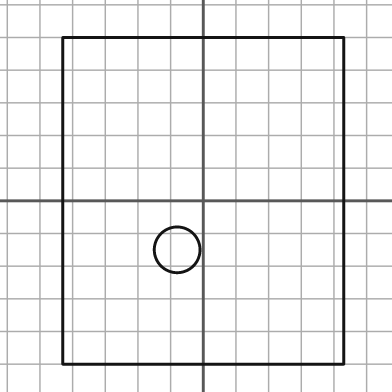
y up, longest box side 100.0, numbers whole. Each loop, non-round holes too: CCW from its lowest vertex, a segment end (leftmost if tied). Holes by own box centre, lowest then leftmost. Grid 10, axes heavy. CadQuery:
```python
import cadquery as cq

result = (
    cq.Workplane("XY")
    .moveTo(-43.0, -50.0)
    .lineTo(43.0, -50.0)
    .lineTo(43.0, 50.0)
    .lineTo(-43.0, 50.0)
    .close()
    .moveTo(-8.0, -15.0)
    .circle(7.0)
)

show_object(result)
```